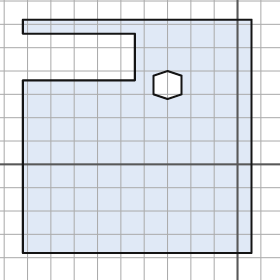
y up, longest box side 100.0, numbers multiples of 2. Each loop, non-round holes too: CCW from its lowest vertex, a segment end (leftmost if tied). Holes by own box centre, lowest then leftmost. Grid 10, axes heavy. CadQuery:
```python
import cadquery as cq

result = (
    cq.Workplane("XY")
    .moveTo(-92.0, -38.0)
    .lineTo(6.0, -38.0)
    .lineTo(6.0, 62.0)
    .lineTo(-92.0, 62.0)
    .lineTo(-92.0, 56.0)
    .lineTo(-44.0, 56.0)
    .lineTo(-44.0, 36.0)
    .lineTo(-92.0, 36.0)
    .close()
    .moveTo(-30.0, 28.0)
    .lineTo(-24.0, 30.0)
    .lineTo(-24.0, 38.0)
    .lineTo(-30.0, 40.0)
    .lineTo(-36.0, 38.0)
    .lineTo(-36.0, 30.0)
    .close()
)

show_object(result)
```